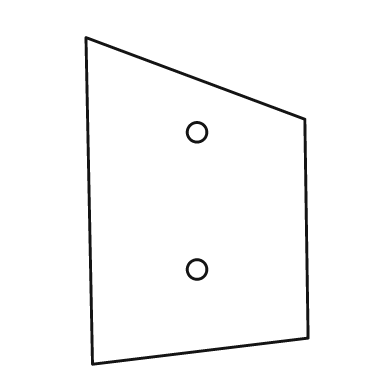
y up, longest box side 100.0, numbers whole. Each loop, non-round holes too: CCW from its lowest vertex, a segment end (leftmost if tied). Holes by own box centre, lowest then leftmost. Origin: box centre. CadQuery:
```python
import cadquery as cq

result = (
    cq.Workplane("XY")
    .moveTo(-32.0, -50.0)
    .lineTo(34.0, -42.0)
    .lineTo(33.0, 25.0)
    .lineTo(-34.0, 50.0)
    .close()
    .moveTo(0.0, -21.0)
    .circle(3.0)
    .moveTo(0.0, 21.0)
    .circle(3.0)
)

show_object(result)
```